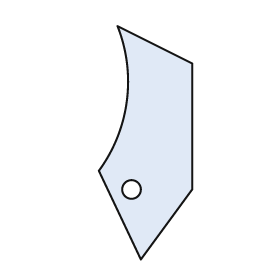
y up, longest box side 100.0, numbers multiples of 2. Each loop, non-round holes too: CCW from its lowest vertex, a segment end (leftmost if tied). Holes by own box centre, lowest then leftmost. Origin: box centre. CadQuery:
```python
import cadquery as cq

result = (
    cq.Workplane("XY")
    .moveTo(-2.0, -50.0)
    .lineTo(20.0, -20.0)
    .lineTo(20.0, 34.0)
    .lineTo(-12.0, 50.0)
    .threePointArc((-8.0, 18.0), (-20.0, -12.0))
    .close()
    .moveTo(-6.0, -20.0)
    .circle(4.0)
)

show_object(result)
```